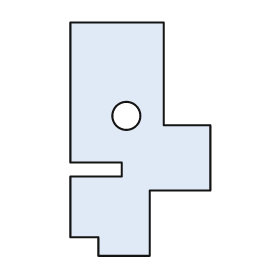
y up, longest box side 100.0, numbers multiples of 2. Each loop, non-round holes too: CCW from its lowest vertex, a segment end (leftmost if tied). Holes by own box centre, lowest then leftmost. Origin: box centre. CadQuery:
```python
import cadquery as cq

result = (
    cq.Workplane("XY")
    .moveTo(-18.0, -50.0)
    .lineTo(4.0, -50.0)
    .lineTo(4.0, -22.0)
    .lineTo(30.0, -22.0)
    .lineTo(30.0, 6.0)
    .lineTo(10.0, 6.0)
    .lineTo(10.0, 50.0)
    .lineTo(-30.0, 50.0)
    .lineTo(-30.0, -10.0)
    .lineTo(-8.0, -10.0)
    .lineTo(-8.0, -16.0)
    .lineTo(-30.0, -16.0)
    .lineTo(-30.0, -42.0)
    .lineTo(-18.0, -42.0)
    .close()
    .moveTo(-6.0, 10.0)
    .circle(6.0)
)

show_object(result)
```